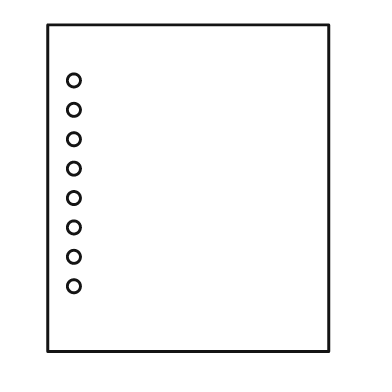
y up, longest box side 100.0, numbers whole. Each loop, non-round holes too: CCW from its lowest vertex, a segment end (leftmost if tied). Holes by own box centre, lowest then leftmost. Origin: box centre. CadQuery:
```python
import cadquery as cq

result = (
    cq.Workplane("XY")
    .moveTo(-43.0, -50.0)
    .lineTo(43.0, -50.0)
    .lineTo(43.0, 50.0)
    .lineTo(-43.0, 50.0)
    .close()
    .moveTo(-35.0, -30.0)
    .circle(2.0)
    .moveTo(-35.0, -21.0)
    .circle(2.0)
    .moveTo(-35.0, -12.0)
    .circle(2.0)
    .moveTo(-35.0, -3.0)
    .circle(2.0)
    .moveTo(-35.0, 6.0)
    .circle(2.0)
    .moveTo(-35.0, 15.0)
    .circle(2.0)
    .moveTo(-35.0, 24.0)
    .circle(2.0)
    .moveTo(-35.0, 33.0)
    .circle(2.0)
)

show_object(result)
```